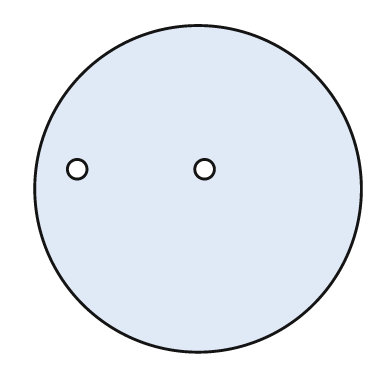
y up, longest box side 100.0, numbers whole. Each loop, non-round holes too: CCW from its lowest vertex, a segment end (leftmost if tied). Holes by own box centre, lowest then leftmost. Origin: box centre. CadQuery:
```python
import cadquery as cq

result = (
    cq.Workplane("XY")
    .moveTo(0.0, 0.0)
    .circle(50.0)
    .moveTo(-37.0, 6.0)
    .circle(3.0)
    .moveTo(2.0, 6.0)
    .circle(3.0)
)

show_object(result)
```